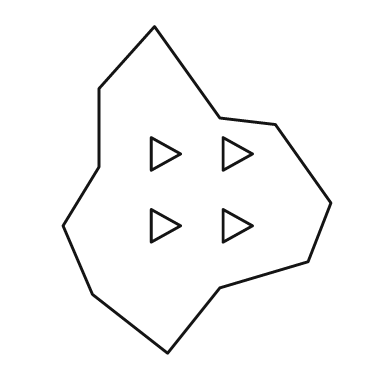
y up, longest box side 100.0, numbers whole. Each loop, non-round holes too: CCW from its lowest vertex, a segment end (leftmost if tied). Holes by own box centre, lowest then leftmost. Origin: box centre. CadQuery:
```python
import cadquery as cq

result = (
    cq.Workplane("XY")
    .moveTo(-9.0, -50.0)
    .lineTo(7.0, -30.0)
    .lineTo(34.0, -22.0)
    .lineTo(41.0, -4.0)
    .lineTo(24.0, 20.0)
    .lineTo(7.0, 22.0)
    .lineTo(-13.0, 50.0)
    .lineTo(-30.0, 31.0)
    .lineTo(-30.0, 7.0)
    .lineTo(-41.0, -11.0)
    .lineTo(-32.0, -32.0)
    .close()
    .moveTo(-14.0, -16.0)
    .lineTo(-5.0, -11.0)
    .lineTo(-14.0, -6.0)
    .close()
    .moveTo(8.0, -16.0)
    .lineTo(17.0, -11.0)
    .lineTo(8.0, -6.0)
    .close()
    .moveTo(-14.0, 6.0)
    .lineTo(-5.0, 11.0)
    .lineTo(-14.0, 16.0)
    .close()
    .moveTo(8.0, 6.0)
    .lineTo(17.0, 11.0)
    .lineTo(8.0, 16.0)
    .close()
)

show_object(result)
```